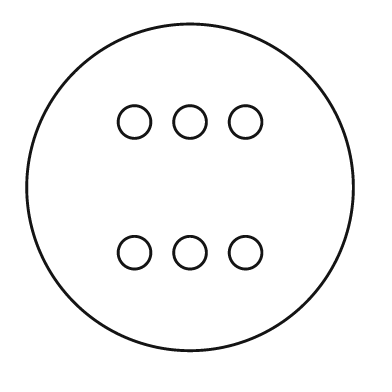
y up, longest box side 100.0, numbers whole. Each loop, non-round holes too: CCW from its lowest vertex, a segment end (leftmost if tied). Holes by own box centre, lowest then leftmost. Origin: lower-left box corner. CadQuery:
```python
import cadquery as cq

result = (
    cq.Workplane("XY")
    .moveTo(50.0, 50.0)
    .circle(50.0)
    .moveTo(33.0, 30.0)
    .circle(5.0)
    .moveTo(50.0, 30.0)
    .circle(5.0)
    .moveTo(67.0, 30.0)
    .circle(5.0)
    .moveTo(33.0, 70.0)
    .circle(5.0)
    .moveTo(50.0, 70.0)
    .circle(5.0)
    .moveTo(67.0, 70.0)
    .circle(5.0)
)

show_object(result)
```